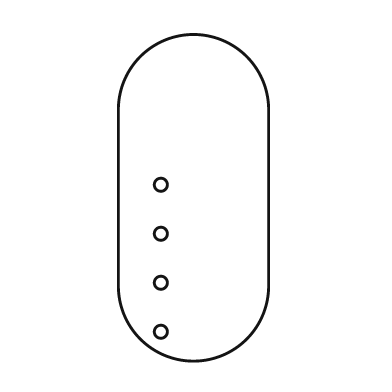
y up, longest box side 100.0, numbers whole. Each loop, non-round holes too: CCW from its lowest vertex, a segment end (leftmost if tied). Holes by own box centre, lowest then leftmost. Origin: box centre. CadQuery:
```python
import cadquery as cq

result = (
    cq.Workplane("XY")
    .moveTo(-23.0, -27.0)
    .threePointArc((0.0, -50.0), (23.0, -27.0))
    .lineTo(23.0, 27.0)
    .threePointArc((0.0, 50.0), (-23.0, 27.0))
    .close()
    .moveTo(-10.0, -41.0)
    .circle(2.0)
    .moveTo(-10.0, -26.0)
    .circle(2.0)
    .moveTo(-10.0, -11.0)
    .circle(2.0)
    .moveTo(-10.0, 4.0)
    .circle(2.0)
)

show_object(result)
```